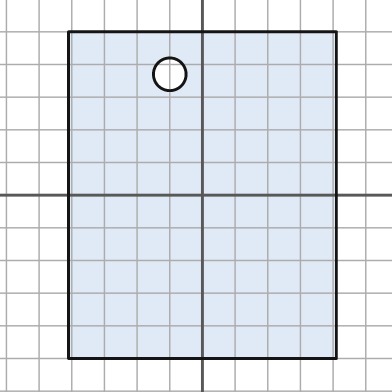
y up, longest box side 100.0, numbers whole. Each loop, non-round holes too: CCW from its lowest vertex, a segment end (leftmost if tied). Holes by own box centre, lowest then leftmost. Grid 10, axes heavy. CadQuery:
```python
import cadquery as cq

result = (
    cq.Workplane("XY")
    .moveTo(-41.0, -50.0)
    .lineTo(41.0, -50.0)
    .lineTo(41.0, 50.0)
    .lineTo(-41.0, 50.0)
    .close()
    .moveTo(-10.0, 37.0)
    .circle(5.0)
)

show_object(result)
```